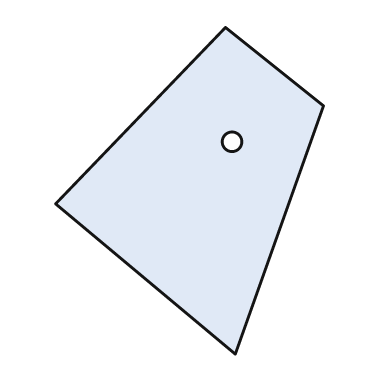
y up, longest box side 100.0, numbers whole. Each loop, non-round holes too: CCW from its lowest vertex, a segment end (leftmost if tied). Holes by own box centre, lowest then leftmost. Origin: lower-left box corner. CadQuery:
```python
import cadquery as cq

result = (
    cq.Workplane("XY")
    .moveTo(55.0, 0.0)
    .lineTo(82.0, 76.0)
    .lineTo(52.0, 100.0)
    .lineTo(0.0, 46.0)
    .close()
    .moveTo(54.0, 65.0)
    .circle(3.0)
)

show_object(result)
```